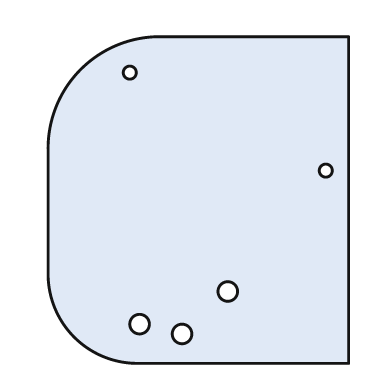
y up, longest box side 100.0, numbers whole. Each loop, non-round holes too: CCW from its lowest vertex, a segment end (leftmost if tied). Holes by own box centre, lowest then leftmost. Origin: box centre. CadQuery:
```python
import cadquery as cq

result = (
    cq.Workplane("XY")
    .moveTo(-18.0, -50.0)
    .lineTo(46.0, -50.0)
    .lineTo(46.0, 50.0)
    .lineTo(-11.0, 50.0)
    .threePointArc((-36.0, 40.0), (-46.0, 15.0))
    .lineTo(-46.0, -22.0)
    .threePointArc((-38.0, -42.0), (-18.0, -50.0))
    .close()
    .moveTo(-5.0, -41.0)
    .circle(3.0)
    .moveTo(-18.0, -38.0)
    .circle(3.0)
    .moveTo(9.0, -28.0)
    .circle(3.0)
    .moveTo(39.0, 9.0)
    .circle(2.0)
    .moveTo(-21.0, 39.0)
    .circle(2.0)
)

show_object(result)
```